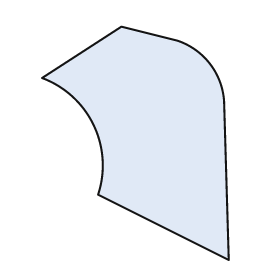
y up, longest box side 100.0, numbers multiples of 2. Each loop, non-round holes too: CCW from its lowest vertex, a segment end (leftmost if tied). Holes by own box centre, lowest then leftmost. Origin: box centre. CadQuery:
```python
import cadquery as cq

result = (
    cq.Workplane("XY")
    .moveTo(40.0, -50.0)
    .lineTo(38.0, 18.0)
    .threePointArc((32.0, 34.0), (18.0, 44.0))
    .lineTo(-6.0, 50.0)
    .lineTo(-40.0, 28.0)
    .threePointArc((-18.0, 8.0), (-16.0, -22.0))
    .close()
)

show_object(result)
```